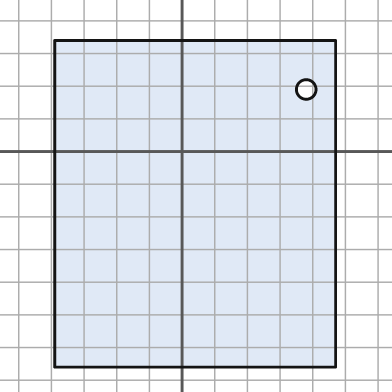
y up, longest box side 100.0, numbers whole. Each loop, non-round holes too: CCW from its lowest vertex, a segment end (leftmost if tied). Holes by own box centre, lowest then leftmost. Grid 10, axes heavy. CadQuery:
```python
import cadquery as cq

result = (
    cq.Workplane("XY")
    .moveTo(-39.0, -66.0)
    .lineTo(47.0, -66.0)
    .lineTo(47.0, 34.0)
    .lineTo(-39.0, 34.0)
    .close()
    .moveTo(38.0, 19.0)
    .circle(3.0)
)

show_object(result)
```